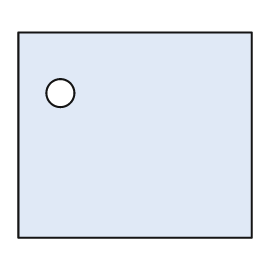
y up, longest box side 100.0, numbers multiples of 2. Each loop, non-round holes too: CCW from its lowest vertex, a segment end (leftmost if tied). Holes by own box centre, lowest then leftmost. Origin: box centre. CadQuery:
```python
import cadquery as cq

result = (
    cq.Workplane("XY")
    .moveTo(-50.0, -44.0)
    .lineTo(50.0, -44.0)
    .lineTo(50.0, 44.0)
    .lineTo(-50.0, 44.0)
    .close()
    .moveTo(-32.0, 18.0)
    .circle(6.0)
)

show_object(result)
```